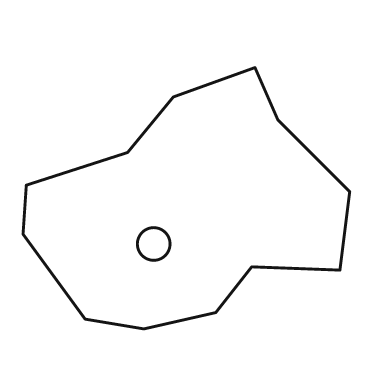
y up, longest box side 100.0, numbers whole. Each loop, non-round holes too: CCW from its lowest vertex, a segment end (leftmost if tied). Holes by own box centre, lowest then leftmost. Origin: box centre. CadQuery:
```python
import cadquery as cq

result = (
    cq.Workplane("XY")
    .moveTo(-13.0, -40.0)
    .lineTo(9.0, -35.0)
    .lineTo(20.0, -21.0)
    .lineTo(47.0, -22.0)
    .lineTo(50.0, 2.0)
    .lineTo(28.0, 24.0)
    .lineTo(21.0, 40.0)
    .lineTo(-4.0, 31.0)
    .lineTo(-18.0, 14.0)
    .lineTo(-49.0, 4.0)
    .lineTo(-50.0, -11.0)
    .lineTo(-31.0, -37.0)
    .close()
    .moveTo(-10.0, -14.0)
    .circle(5.0)
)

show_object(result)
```